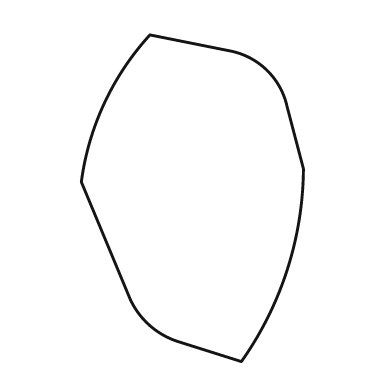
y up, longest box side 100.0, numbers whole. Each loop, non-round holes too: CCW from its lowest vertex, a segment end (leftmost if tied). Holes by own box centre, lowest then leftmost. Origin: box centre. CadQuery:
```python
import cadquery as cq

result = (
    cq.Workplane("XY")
    .moveTo(15.0, -50.0)
    .threePointArc((29.0, -22.0), (34.0, 9.0))
    .lineTo(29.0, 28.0)
    .threePointArc((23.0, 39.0), (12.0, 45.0))
    .lineTo(-13.0, 50.0)
    .threePointArc((-27.0, 29.0), (-34.0, 5.0))
    .lineTo(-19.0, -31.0)
    .threePointArc((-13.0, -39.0), (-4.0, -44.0))
    .close()
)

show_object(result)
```